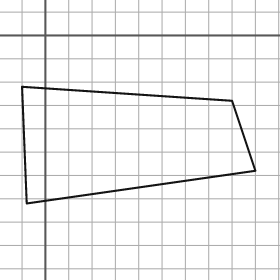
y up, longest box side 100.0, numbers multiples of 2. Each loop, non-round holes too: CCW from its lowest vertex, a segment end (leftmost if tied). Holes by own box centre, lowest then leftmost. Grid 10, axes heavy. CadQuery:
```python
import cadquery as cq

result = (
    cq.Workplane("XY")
    .moveTo(-8.0, -72.0)
    .lineTo(90.0, -58.0)
    .lineTo(80.0, -28.0)
    .lineTo(-10.0, -22.0)
    .close()
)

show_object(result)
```